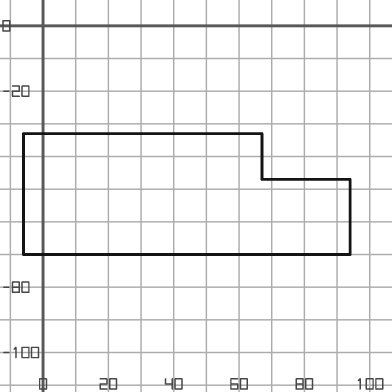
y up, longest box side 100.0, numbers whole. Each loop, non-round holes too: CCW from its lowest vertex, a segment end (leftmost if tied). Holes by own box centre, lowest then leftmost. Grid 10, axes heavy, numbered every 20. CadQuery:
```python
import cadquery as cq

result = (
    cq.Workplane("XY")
    .moveTo(-6.0, -70.0)
    .lineTo(94.0, -70.0)
    .lineTo(94.0, -47.0)
    .lineTo(67.0, -47.0)
    .lineTo(67.0, -33.0)
    .lineTo(-6.0, -33.0)
    .close()
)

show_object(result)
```